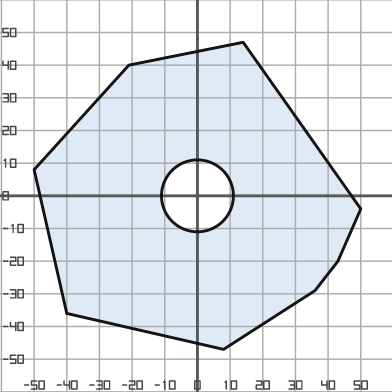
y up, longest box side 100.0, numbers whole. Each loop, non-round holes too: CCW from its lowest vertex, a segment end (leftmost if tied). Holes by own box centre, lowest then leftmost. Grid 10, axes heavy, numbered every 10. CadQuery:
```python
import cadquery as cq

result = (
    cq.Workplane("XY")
    .moveTo(8.0, -47.0)
    .lineTo(36.0, -29.0)
    .lineTo(43.0, -20.0)
    .lineTo(50.0, -4.0)
    .lineTo(14.0, 47.0)
    .lineTo(-21.0, 40.0)
    .lineTo(-50.0, 8.0)
    .lineTo(-40.0, -36.0)
    .close()
    .moveTo(0.0, 0.0)
    .circle(11.0)
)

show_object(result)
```